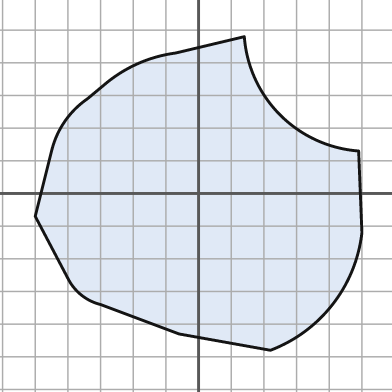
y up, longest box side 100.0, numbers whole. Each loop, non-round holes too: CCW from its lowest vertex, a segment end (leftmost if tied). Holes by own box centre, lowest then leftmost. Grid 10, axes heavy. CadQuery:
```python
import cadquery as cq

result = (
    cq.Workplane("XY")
    .moveTo(22.0, -48.0)
    .threePointArc((41.0, -34.0), (50.0, -12.0))
    .lineTo(49.0, 13.0)
    .threePointArc((25.0, 24.0), (14.0, 48.0))
    .lineTo(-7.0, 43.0)
    .threePointArc((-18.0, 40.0), (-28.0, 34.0))
    .lineTo(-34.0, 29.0)
    .threePointArc((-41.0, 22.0), (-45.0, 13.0))
    .lineTo(-50.0, -7.0)
    .lineTo(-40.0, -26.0)
    .threePointArc((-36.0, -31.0), (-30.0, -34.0))
    .lineTo(-6.0, -43.0)
    .close()
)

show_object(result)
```